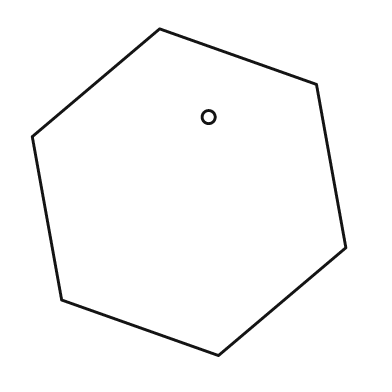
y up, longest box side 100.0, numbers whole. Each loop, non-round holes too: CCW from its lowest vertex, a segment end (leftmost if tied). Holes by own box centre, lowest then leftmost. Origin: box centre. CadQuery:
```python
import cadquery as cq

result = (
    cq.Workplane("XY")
    .moveTo(9.0, -50.0)
    .lineTo(48.0, -17.0)
    .lineTo(39.0, 33.0)
    .lineTo(-9.0, 50.0)
    .lineTo(-48.0, 17.0)
    .lineTo(-39.0, -33.0)
    .close()
    .moveTo(6.0, 23.0)
    .circle(2.0)
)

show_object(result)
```